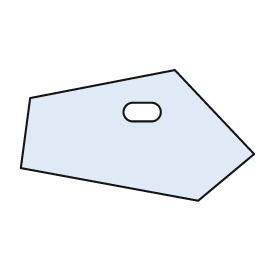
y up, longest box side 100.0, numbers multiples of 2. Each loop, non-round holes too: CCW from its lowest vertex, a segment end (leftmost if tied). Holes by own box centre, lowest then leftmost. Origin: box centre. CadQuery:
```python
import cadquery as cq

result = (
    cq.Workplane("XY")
    .moveTo(26.0, -28.0)
    .lineTo(50.0, -8.0)
    .lineTo(16.0, 28.0)
    .lineTo(-46.0, 16.0)
    .lineTo(-50.0, -14.0)
    .close()
    .moveTo(-2.0, 6.0)
    .lineTo(6.0, 6.0)
    .threePointArc((10.0, 10.0), (6.0, 14.0))
    .lineTo(-2.0, 14.0)
    .threePointArc((-6.0, 10.0), (-2.0, 6.0))
    .close()
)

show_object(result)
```